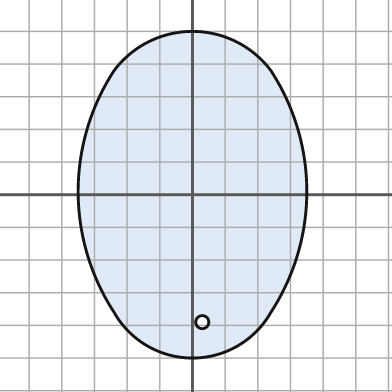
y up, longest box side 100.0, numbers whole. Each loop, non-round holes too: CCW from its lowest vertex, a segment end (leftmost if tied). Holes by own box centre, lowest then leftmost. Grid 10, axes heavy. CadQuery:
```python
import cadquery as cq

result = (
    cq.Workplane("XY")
    .moveTo(-24.0, -36.0)
    .threePointArc((0.0, -50.0), (24.0, -36.0))
    .threePointArc((35.0, 1.0), (24.0, 38.0))
    .threePointArc((0.0, 50.0), (-24.0, 38.0))
    .threePointArc((-35.0, 1.0), (-24.0, -36.0))
    .close()
    .moveTo(3.0, -39.0)
    .circle(2.0)
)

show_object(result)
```